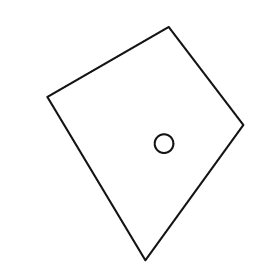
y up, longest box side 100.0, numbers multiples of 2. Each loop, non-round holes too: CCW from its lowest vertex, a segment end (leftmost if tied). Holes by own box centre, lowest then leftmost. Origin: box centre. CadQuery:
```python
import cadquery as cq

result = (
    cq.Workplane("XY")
    .moveTo(0.0, -50.0)
    .lineTo(42.0, 8.0)
    .lineTo(10.0, 50.0)
    .lineTo(-42.0, 20.0)
    .close()
    .moveTo(8.0, 0.0)
    .circle(4.0)
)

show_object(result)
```